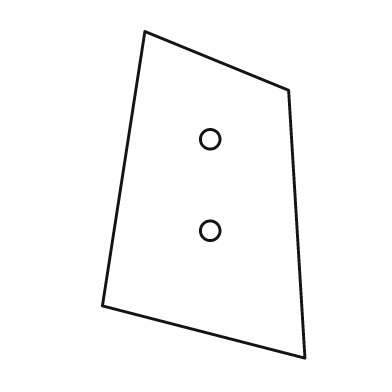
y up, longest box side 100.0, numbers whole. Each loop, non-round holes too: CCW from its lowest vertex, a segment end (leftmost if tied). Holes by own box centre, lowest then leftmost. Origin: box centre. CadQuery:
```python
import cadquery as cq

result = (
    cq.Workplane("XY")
    .moveTo(31.0, -50.0)
    .lineTo(26.0, 32.0)
    .lineTo(-18.0, 50.0)
    .lineTo(-31.0, -34.0)
    .close()
    .moveTo(2.0, -11.0)
    .circle(3.0)
    .moveTo(2.0, 17.0)
    .circle(3.0)
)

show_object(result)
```